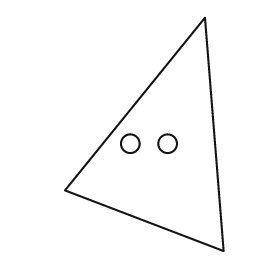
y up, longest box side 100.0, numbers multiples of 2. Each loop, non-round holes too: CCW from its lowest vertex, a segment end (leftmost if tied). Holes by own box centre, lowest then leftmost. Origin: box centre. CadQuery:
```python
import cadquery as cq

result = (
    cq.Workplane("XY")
    .moveTo(34.0, -50.0)
    .lineTo(26.0, 50.0)
    .lineTo(-34.0, -24.0)
    .close()
    .moveTo(-6.0, -4.0)
    .circle(4.0)
    .moveTo(10.0, -4.0)
    .circle(4.0)
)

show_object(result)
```